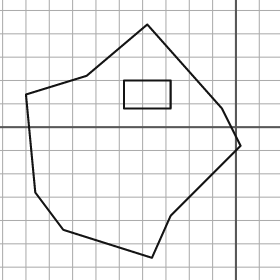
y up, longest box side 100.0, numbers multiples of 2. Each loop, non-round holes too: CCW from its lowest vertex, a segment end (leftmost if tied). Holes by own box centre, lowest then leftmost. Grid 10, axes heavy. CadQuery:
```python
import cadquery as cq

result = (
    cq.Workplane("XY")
    .moveTo(-36.0, -56.0)
    .lineTo(-28.0, -38.0)
    .lineTo(2.0, -8.0)
    .lineTo(-6.0, 8.0)
    .lineTo(-38.0, 44.0)
    .lineTo(-64.0, 22.0)
    .lineTo(-90.0, 14.0)
    .lineTo(-86.0, -28.0)
    .lineTo(-74.0, -44.0)
    .close()
    .moveTo(-48.0, 8.0)
    .lineTo(-28.0, 8.0)
    .lineTo(-28.0, 20.0)
    .lineTo(-48.0, 20.0)
    .close()
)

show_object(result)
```